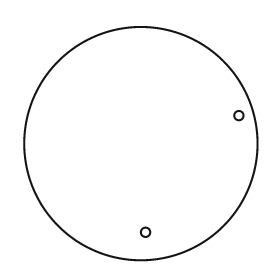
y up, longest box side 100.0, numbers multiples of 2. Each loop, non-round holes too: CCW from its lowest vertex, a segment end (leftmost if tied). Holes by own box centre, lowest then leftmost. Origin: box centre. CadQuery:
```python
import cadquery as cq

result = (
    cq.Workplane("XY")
    .moveTo(0.0, 0.0)
    .circle(50.0)
    .moveTo(2.0, -38.0)
    .circle(2.0)
    .moveTo(42.0, 12.0)
    .circle(2.0)
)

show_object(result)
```